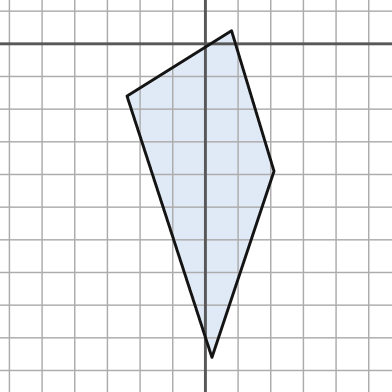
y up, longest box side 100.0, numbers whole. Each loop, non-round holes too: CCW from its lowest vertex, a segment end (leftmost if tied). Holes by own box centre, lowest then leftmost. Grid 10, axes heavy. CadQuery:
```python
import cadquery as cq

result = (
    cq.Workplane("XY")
    .moveTo(2.0, -96.0)
    .lineTo(21.0, -39.0)
    .lineTo(8.0, 4.0)
    .lineTo(-24.0, -16.0)
    .close()
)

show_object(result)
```